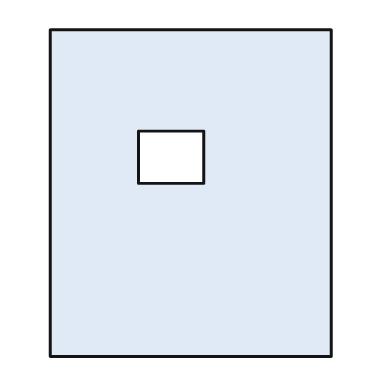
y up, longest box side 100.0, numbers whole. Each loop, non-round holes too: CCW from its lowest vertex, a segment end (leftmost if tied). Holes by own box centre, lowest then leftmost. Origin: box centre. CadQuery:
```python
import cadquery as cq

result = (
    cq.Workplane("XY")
    .moveTo(-43.0, -50.0)
    .lineTo(43.0, -50.0)
    .lineTo(43.0, 50.0)
    .lineTo(-43.0, 50.0)
    .close()
    .moveTo(-16.0, 3.0)
    .lineTo(4.0, 3.0)
    .lineTo(4.0, 19.0)
    .lineTo(-16.0, 19.0)
    .close()
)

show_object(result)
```